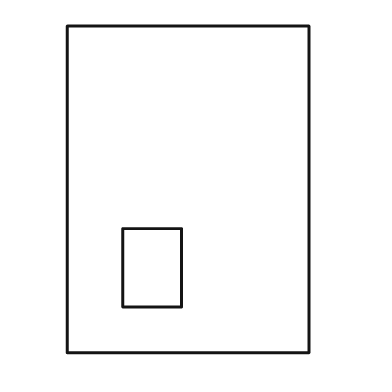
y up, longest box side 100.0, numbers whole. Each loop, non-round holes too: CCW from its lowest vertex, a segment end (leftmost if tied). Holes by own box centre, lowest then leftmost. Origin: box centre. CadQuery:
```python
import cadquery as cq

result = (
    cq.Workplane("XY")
    .moveTo(-37.0, -50.0)
    .lineTo(37.0, -50.0)
    .lineTo(37.0, 50.0)
    .lineTo(-37.0, 50.0)
    .close()
    .moveTo(-20.0, -36.0)
    .lineTo(-2.0, -36.0)
    .lineTo(-2.0, -12.0)
    .lineTo(-20.0, -12.0)
    .close()
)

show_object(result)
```